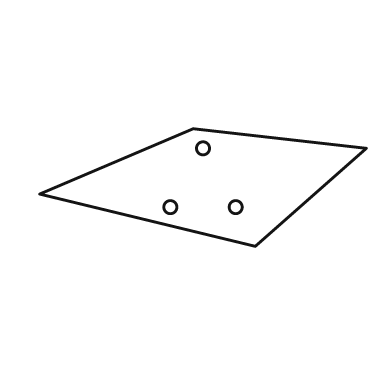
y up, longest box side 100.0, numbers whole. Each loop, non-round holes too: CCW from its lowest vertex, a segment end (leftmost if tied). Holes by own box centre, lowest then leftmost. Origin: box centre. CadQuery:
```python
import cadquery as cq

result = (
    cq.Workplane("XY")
    .moveTo(16.0, -18.0)
    .lineTo(50.0, 12.0)
    .lineTo(-3.0, 18.0)
    .lineTo(-50.0, -2.0)
    .close()
    .moveTo(-10.0, -6.0)
    .circle(2.0)
    .moveTo(10.0, -6.0)
    .circle(2.0)
    .moveTo(0.0, 12.0)
    .circle(2.0)
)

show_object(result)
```